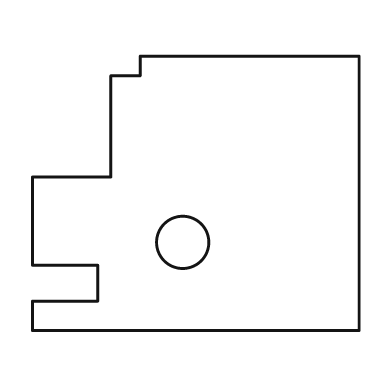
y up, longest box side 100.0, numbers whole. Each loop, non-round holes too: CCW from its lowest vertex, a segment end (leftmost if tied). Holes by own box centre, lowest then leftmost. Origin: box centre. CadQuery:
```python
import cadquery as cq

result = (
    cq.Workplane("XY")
    .moveTo(-50.0, -42.0)
    .lineTo(50.0, -42.0)
    .lineTo(50.0, 42.0)
    .lineTo(-17.0, 42.0)
    .lineTo(-17.0, 36.0)
    .lineTo(-26.0, 36.0)
    .lineTo(-26.0, 5.0)
    .lineTo(-50.0, 5.0)
    .lineTo(-50.0, -22.0)
    .lineTo(-30.0, -22.0)
    .lineTo(-30.0, -33.0)
    .lineTo(-50.0, -33.0)
    .close()
    .moveTo(-4.0, -15.0)
    .circle(8.0)
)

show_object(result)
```